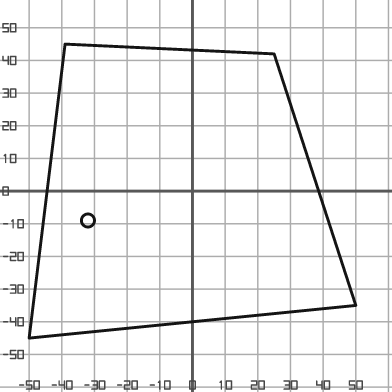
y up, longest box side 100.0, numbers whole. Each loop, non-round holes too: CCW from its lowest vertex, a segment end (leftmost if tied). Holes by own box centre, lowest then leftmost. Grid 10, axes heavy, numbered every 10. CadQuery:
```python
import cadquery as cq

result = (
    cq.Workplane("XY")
    .moveTo(-50.0, -45.0)
    .lineTo(50.0, -35.0)
    .lineTo(25.0, 42.0)
    .lineTo(-39.0, 45.0)
    .close()
    .moveTo(-32.0, -9.0)
    .circle(2.0)
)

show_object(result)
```